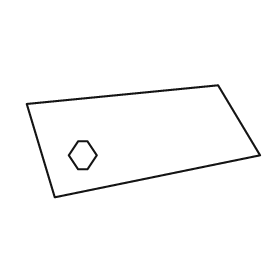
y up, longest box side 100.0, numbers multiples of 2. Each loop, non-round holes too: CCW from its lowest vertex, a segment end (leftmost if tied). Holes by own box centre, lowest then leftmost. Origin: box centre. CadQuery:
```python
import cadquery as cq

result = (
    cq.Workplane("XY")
    .moveTo(-38.0, -24.0)
    .lineTo(50.0, -6.0)
    .lineTo(32.0, 24.0)
    .lineTo(-50.0, 16.0)
    .close()
    .moveTo(-28.0, -12.0)
    .lineTo(-24.0, -12.0)
    .lineTo(-20.0, -6.0)
    .lineTo(-24.0, 0.0)
    .lineTo(-28.0, 0.0)
    .lineTo(-32.0, -6.0)
    .close()
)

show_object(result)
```